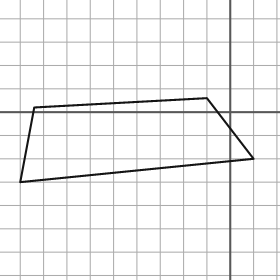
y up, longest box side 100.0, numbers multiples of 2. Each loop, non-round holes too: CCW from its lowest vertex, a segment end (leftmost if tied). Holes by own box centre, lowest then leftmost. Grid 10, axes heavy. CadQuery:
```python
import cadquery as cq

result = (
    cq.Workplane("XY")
    .moveTo(-90.0, -30.0)
    .lineTo(10.0, -20.0)
    .lineTo(-10.0, 6.0)
    .lineTo(-84.0, 2.0)
    .close()
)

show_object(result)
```